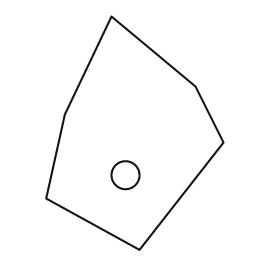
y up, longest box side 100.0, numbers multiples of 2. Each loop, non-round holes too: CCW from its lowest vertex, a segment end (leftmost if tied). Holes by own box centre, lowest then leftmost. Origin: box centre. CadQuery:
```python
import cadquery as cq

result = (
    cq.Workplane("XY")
    .moveTo(2.0, -50.0)
    .lineTo(38.0, -4.0)
    .lineTo(26.0, 20.0)
    .lineTo(-10.0, 50.0)
    .lineTo(-30.0, 8.0)
    .lineTo(-38.0, -28.0)
    .close()
    .moveTo(-4.0, -18.0)
    .circle(6.0)
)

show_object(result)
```